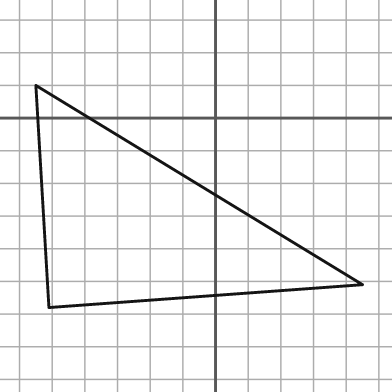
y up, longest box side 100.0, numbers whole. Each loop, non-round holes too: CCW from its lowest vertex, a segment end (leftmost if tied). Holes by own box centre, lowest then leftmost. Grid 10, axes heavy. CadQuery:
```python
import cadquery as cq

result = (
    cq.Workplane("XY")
    .moveTo(-51.0, -58.0)
    .lineTo(45.0, -51.0)
    .lineTo(-55.0, 10.0)
    .close()
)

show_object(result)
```